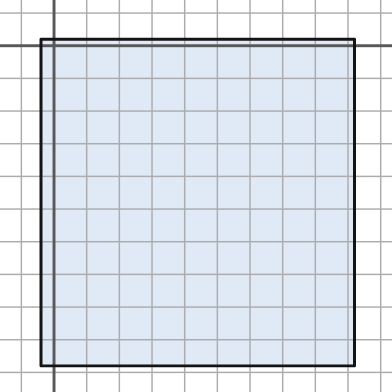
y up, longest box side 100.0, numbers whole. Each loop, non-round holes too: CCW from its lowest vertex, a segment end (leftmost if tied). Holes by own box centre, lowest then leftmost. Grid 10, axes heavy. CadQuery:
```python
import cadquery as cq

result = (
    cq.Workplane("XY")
    .moveTo(-4.0, -98.0)
    .lineTo(92.0, -98.0)
    .lineTo(92.0, 2.0)
    .lineTo(-4.0, 2.0)
    .close()
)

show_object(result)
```